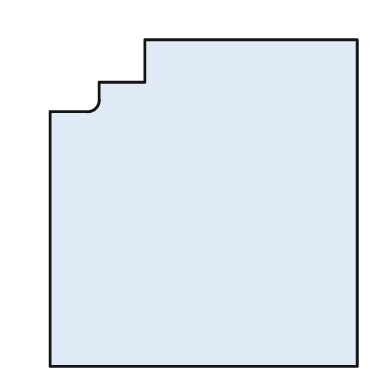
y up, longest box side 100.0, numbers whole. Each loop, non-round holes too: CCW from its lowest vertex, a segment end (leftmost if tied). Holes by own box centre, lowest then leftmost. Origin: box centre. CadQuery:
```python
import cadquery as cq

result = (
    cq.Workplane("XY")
    .moveTo(-47.0, -50.0)
    .lineTo(47.0, -50.0)
    .lineTo(47.0, 50.0)
    .lineTo(-18.0, 50.0)
    .lineTo(-18.0, 37.0)
    .lineTo(-32.0, 37.0)
    .lineTo(-32.0, 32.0)
    .threePointArc((-33.0, 29.0), (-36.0, 28.0))
    .lineTo(-47.0, 28.0)
    .close()
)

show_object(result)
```